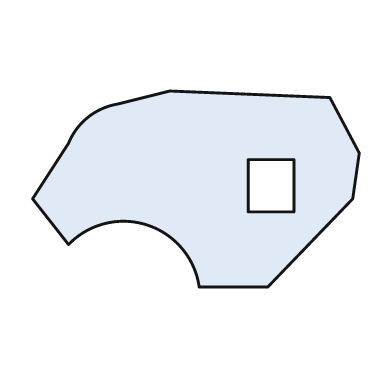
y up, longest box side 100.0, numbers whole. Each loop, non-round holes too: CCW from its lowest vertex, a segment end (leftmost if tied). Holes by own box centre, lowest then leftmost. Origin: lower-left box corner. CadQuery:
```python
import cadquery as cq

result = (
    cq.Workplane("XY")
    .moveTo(51.0, 0.0)
    .lineTo(72.0, 0.0)
    .lineTo(98.0, 27.0)
    .lineTo(100.0, 41.0)
    .lineTo(91.0, 58.0)
    .lineTo(42.0, 60.0)
    .lineTo(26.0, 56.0)
    .threePointArc((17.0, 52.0), (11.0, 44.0))
    .lineTo(0.0, 27.0)
    .lineTo(11.0, 13.0)
    .threePointArc((35.0, 19.0), (51.0, 0.0))
    .close()
    .moveTo(66.0, 23.0)
    .lineTo(80.0, 23.0)
    .lineTo(80.0, 39.0)
    .lineTo(66.0, 39.0)
    .close()
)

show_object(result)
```